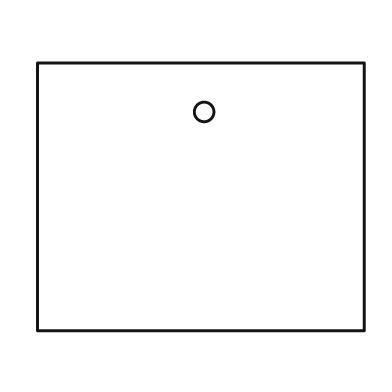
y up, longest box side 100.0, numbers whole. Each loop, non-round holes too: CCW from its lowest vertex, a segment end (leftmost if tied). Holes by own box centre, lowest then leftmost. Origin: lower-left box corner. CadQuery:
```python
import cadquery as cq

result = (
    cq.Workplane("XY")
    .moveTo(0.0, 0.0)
    .lineTo(100.0, 0.0)
    .lineTo(100.0, 82.0)
    .lineTo(0.0, 82.0)
    .close()
    .moveTo(51.0, 67.0)
    .circle(3.0)
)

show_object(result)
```